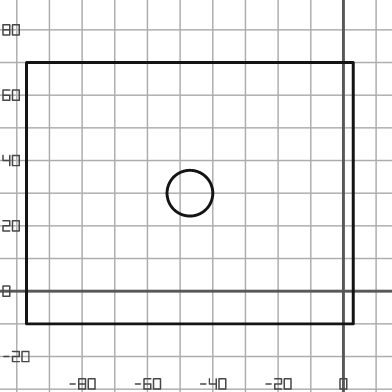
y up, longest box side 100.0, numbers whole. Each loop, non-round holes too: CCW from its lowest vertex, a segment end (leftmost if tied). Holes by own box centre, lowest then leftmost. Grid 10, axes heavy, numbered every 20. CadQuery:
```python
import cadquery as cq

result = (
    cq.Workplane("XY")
    .moveTo(-97.0, -10.0)
    .lineTo(3.0, -10.0)
    .lineTo(3.0, 70.0)
    .lineTo(-97.0, 70.0)
    .close()
    .moveTo(-47.0, 30.0)
    .circle(7.0)
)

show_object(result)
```